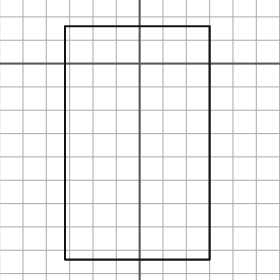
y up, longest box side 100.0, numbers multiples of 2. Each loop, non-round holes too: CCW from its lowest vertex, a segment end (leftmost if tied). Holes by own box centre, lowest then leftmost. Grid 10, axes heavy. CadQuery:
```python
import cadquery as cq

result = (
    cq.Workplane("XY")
    .moveTo(-32.0, -84.0)
    .lineTo(30.0, -84.0)
    .lineTo(30.0, 16.0)
    .lineTo(-32.0, 16.0)
    .close()
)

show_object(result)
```